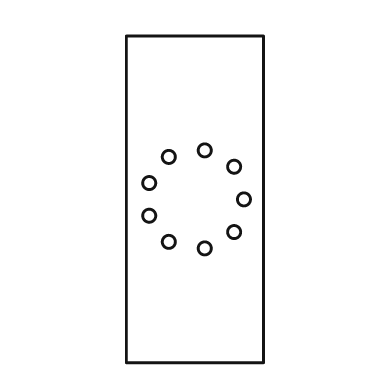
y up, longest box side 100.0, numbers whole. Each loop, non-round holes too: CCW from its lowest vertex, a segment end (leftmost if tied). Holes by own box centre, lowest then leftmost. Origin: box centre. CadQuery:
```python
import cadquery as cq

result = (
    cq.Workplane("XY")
    .moveTo(-21.0, -50.0)
    .lineTo(21.0, -50.0)
    .lineTo(21.0, 50.0)
    .lineTo(-21.0, 50.0)
    .close()
    .moveTo(3.0, -15.0)
    .circle(2.0)
    .moveTo(-8.0, -13.0)
    .circle(2.0)
    .moveTo(12.0, -10.0)
    .circle(2.0)
    .moveTo(-14.0, -5.0)
    .circle(2.0)
    .moveTo(15.0, 0.0)
    .circle(2.0)
    .moveTo(-14.0, 5.0)
    .circle(2.0)
    .moveTo(12.0, 10.0)
    .circle(2.0)
    .moveTo(-8.0, 13.0)
    .circle(2.0)
    .moveTo(3.0, 15.0)
    .circle(2.0)
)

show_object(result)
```